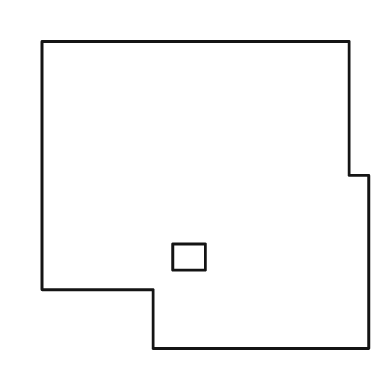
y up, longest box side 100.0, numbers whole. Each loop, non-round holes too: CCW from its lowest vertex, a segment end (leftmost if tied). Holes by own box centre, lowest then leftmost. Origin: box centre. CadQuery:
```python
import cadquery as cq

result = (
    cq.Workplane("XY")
    .moveTo(-16.0, -47.0)
    .lineTo(50.0, -47.0)
    .lineTo(50.0, 6.0)
    .lineTo(44.0, 6.0)
    .lineTo(44.0, 47.0)
    .lineTo(-50.0, 47.0)
    .lineTo(-50.0, -29.0)
    .lineTo(-16.0, -29.0)
    .close()
    .moveTo(-10.0, -23.0)
    .lineTo(0.0, -23.0)
    .lineTo(0.0, -15.0)
    .lineTo(-10.0, -15.0)
    .close()
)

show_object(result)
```